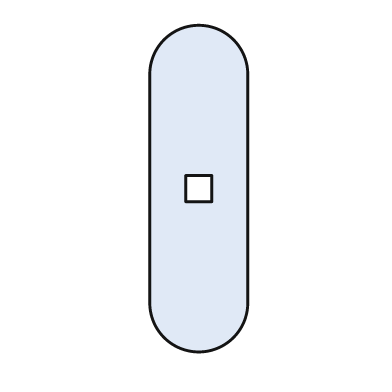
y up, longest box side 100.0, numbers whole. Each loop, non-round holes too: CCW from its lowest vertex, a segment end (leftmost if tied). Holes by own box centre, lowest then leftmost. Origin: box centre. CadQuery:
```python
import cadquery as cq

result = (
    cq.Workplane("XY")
    .moveTo(-15.0, -35.0)
    .threePointArc((0.0, -50.0), (15.0, -35.0))
    .lineTo(15.0, 35.0)
    .threePointArc((0.0, 50.0), (-15.0, 35.0))
    .close()
    .moveTo(-4.0, -4.0)
    .lineTo(4.0, -4.0)
    .lineTo(4.0, 4.0)
    .lineTo(-4.0, 4.0)
    .close()
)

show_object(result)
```